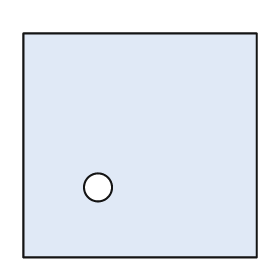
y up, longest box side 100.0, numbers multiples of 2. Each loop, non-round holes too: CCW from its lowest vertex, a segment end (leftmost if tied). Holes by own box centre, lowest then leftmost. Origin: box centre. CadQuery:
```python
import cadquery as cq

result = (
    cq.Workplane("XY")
    .moveTo(-50.0, -48.0)
    .lineTo(50.0, -48.0)
    .lineTo(50.0, 48.0)
    .lineTo(-50.0, 48.0)
    .close()
    .moveTo(-18.0, -18.0)
    .circle(6.0)
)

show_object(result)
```